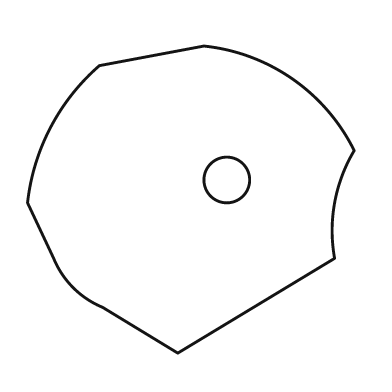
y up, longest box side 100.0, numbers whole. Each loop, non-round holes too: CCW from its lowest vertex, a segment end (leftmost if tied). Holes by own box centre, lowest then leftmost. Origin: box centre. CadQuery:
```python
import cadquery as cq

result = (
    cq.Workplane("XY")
    .moveTo(-4.0, -47.0)
    .lineTo(44.0, -18.0)
    .threePointArc((44.0, -1.0), (50.0, 15.0))
    .threePointArc((31.0, 37.0), (4.0, 47.0))
    .lineTo(-28.0, 41.0)
    .threePointArc((-43.0, 22.0), (-50.0, -1.0))
    .lineTo(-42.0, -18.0)
    .threePointArc((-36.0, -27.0), (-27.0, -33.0))
    .close()
    .moveTo(11.0, 6.0)
    .circle(7.0)
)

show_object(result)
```